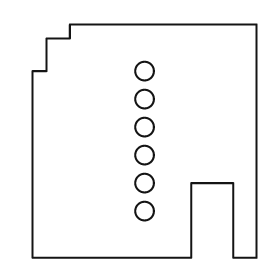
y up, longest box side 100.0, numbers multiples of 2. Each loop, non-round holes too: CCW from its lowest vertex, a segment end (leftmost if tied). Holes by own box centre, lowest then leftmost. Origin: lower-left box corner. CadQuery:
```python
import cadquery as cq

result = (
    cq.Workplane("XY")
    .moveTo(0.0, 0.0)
    .lineTo(68.0, 0.0)
    .lineTo(68.0, 32.0)
    .lineTo(86.0, 32.0)
    .lineTo(86.0, 0.0)
    .lineTo(96.0, 0.0)
    .lineTo(96.0, 100.0)
    .lineTo(16.0, 100.0)
    .lineTo(16.0, 94.0)
    .lineTo(6.0, 94.0)
    .lineTo(6.0, 80.0)
    .lineTo(0.0, 80.0)
    .close()
    .moveTo(48.0, 20.0)
    .circle(4.0)
    .moveTo(48.0, 32.0)
    .circle(4.0)
    .moveTo(48.0, 44.0)
    .circle(4.0)
    .moveTo(48.0, 56.0)
    .circle(4.0)
    .moveTo(48.0, 68.0)
    .circle(4.0)
    .moveTo(48.0, 80.0)
    .circle(4.0)
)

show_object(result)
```